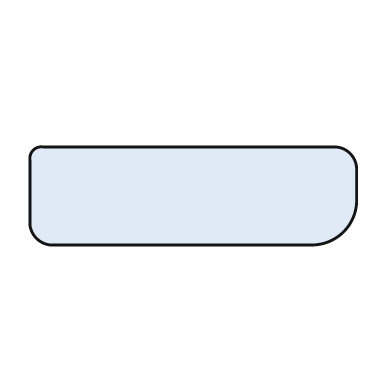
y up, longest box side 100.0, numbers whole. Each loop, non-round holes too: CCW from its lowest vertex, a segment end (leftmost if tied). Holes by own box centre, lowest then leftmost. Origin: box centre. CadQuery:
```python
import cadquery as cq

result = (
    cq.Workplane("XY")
    .moveTo(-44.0, -15.0)
    .lineTo(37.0, -15.0)
    .threePointArc((46.0, -11.0), (50.0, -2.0))
    .lineTo(50.0, 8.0)
    .threePointArc((48.0, 13.0), (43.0, 15.0))
    .lineTo(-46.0, 15.0)
    .threePointArc((-49.0, 14.0), (-50.0, 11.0))
    .lineTo(-50.0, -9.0)
    .threePointArc((-48.0, -13.0), (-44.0, -15.0))
    .close()
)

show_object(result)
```